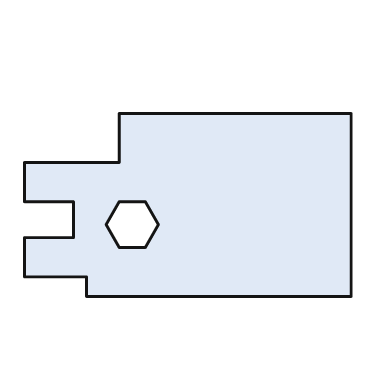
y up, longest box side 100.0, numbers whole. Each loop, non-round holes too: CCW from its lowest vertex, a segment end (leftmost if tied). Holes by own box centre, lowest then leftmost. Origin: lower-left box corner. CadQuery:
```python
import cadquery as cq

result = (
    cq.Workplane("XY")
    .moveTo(19.0, 0.0)
    .lineTo(100.0, 0.0)
    .lineTo(100.0, 56.0)
    .lineTo(29.0, 56.0)
    .lineTo(29.0, 41.0)
    .lineTo(0.0, 41.0)
    .lineTo(0.0, 29.0)
    .lineTo(15.0, 29.0)
    .lineTo(15.0, 18.0)
    .lineTo(0.0, 18.0)
    .lineTo(0.0, 6.0)
    .lineTo(19.0, 6.0)
    .close()
    .moveTo(29.0, 15.0)
    .lineTo(37.0, 15.0)
    .lineTo(41.0, 22.0)
    .lineTo(37.0, 29.0)
    .lineTo(29.0, 29.0)
    .lineTo(25.0, 22.0)
    .close()
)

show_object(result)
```